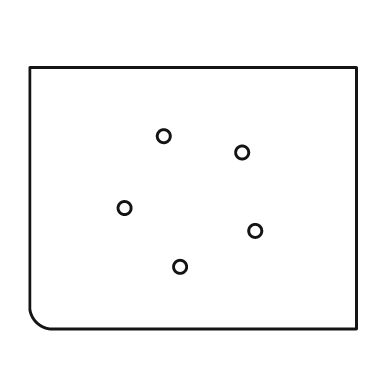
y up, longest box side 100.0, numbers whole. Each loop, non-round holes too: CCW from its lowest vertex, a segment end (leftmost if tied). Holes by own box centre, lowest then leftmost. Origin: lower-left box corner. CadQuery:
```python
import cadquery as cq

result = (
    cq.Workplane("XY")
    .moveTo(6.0, 0.0)
    .lineTo(100.0, 0.0)
    .lineTo(100.0, 80.0)
    .lineTo(0.0, 80.0)
    .lineTo(0.0, 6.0)
    .threePointArc((2.0, 2.0), (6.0, 0.0))
    .close()
    .moveTo(46.0, 19.0)
    .circle(2.0)
    .moveTo(69.0, 30.0)
    .circle(2.0)
    .moveTo(29.0, 37.0)
    .circle(2.0)
    .moveTo(65.0, 54.0)
    .circle(2.0)
    .moveTo(41.0, 59.0)
    .circle(2.0)
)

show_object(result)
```